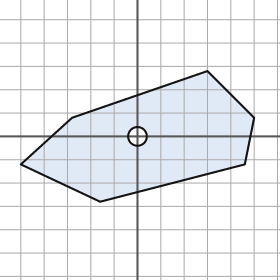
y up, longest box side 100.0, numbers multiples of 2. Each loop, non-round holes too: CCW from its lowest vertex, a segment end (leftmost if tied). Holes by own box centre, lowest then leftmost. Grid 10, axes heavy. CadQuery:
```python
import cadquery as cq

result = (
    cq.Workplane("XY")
    .moveTo(-16.0, -28.0)
    .lineTo(46.0, -12.0)
    .lineTo(50.0, 8.0)
    .lineTo(30.0, 28.0)
    .lineTo(-28.0, 8.0)
    .lineTo(-50.0, -12.0)
    .close()
    .moveTo(0.0, 0.0)
    .circle(4.0)
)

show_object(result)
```